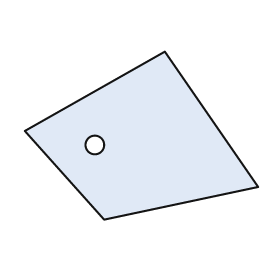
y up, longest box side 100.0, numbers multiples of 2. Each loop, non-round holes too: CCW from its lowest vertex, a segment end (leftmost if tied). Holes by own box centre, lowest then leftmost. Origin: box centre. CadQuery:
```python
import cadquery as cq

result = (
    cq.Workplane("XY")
    .moveTo(-16.0, -36.0)
    .lineTo(50.0, -22.0)
    .lineTo(10.0, 36.0)
    .lineTo(-50.0, 2.0)
    .close()
    .moveTo(-20.0, -4.0)
    .circle(4.0)
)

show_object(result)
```